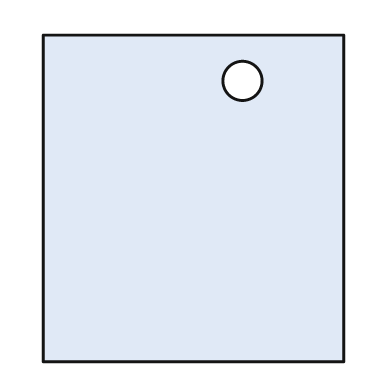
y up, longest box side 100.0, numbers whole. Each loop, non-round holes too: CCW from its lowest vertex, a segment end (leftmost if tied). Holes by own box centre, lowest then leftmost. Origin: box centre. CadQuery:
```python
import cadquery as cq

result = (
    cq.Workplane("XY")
    .moveTo(-46.0, -50.0)
    .lineTo(46.0, -50.0)
    .lineTo(46.0, 50.0)
    .lineTo(-46.0, 50.0)
    .close()
    .moveTo(15.0, 36.0)
    .circle(6.0)
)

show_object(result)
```